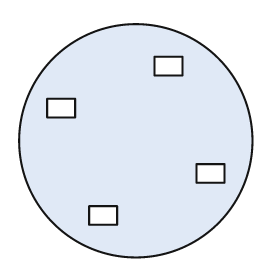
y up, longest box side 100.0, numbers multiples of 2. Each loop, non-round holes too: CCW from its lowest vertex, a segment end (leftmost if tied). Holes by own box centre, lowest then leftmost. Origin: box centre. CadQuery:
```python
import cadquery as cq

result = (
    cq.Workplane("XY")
    .moveTo(0.0, 0.0)
    .circle(50.0)
    .moveTo(-20.0, -36.0)
    .lineTo(-8.0, -36.0)
    .lineTo(-8.0, -28.0)
    .lineTo(-20.0, -28.0)
    .close()
    .moveTo(26.0, -18.0)
    .lineTo(38.0, -18.0)
    .lineTo(38.0, -10.0)
    .lineTo(26.0, -10.0)
    .close()
    .moveTo(-38.0, 10.0)
    .lineTo(-26.0, 10.0)
    .lineTo(-26.0, 18.0)
    .lineTo(-38.0, 18.0)
    .close()
    .moveTo(8.0, 28.0)
    .lineTo(20.0, 28.0)
    .lineTo(20.0, 36.0)
    .lineTo(8.0, 36.0)
    .close()
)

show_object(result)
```